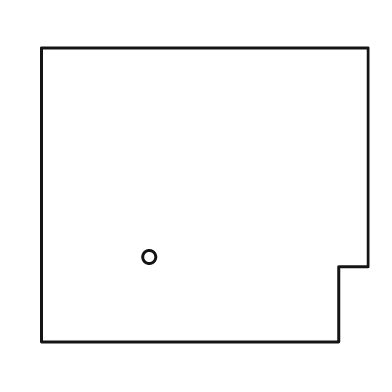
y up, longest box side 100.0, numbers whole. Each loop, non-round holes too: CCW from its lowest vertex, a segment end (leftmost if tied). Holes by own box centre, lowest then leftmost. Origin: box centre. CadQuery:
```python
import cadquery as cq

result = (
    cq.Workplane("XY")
    .moveTo(-50.0, -45.0)
    .lineTo(41.0, -45.0)
    .lineTo(41.0, -22.0)
    .lineTo(50.0, -22.0)
    .lineTo(50.0, 45.0)
    .lineTo(-50.0, 45.0)
    .close()
    .moveTo(-17.0, -19.0)
    .circle(2.0)
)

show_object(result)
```